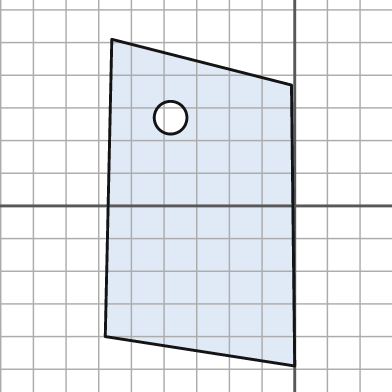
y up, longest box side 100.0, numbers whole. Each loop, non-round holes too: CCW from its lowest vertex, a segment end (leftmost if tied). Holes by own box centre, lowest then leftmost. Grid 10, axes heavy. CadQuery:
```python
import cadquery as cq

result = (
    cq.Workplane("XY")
    .moveTo(0.0, -49.0)
    .lineTo(-1.0, 37.0)
    .lineTo(-56.0, 51.0)
    .lineTo(-58.0, -40.0)
    .close()
    .moveTo(-38.0, 27.0)
    .circle(5.0)
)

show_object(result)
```